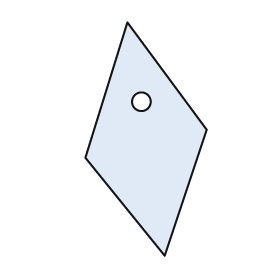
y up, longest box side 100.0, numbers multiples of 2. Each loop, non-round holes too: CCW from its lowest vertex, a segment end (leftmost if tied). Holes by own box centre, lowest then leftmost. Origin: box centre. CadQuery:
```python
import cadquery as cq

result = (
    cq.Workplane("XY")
    .moveTo(8.0, -50.0)
    .lineTo(26.0, 4.0)
    .lineTo(-8.0, 50.0)
    .lineTo(-26.0, -8.0)
    .close()
    .moveTo(-2.0, 16.0)
    .circle(4.0)
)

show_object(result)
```